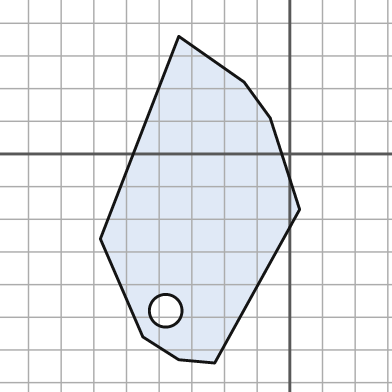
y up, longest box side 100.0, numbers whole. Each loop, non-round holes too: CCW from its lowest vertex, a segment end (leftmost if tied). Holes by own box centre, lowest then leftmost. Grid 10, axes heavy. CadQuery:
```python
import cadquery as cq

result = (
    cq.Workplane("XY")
    .moveTo(-23.0, -64.0)
    .lineTo(3.0, -17.0)
    .lineTo(-6.0, 11.0)
    .lineTo(-14.0, 22.0)
    .lineTo(-34.0, 36.0)
    .lineTo(-58.0, -26.0)
    .lineTo(-45.0, -56.0)
    .lineTo(-34.0, -63.0)
    .close()
    .moveTo(-38.0, -48.0)
    .circle(5.0)
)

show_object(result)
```